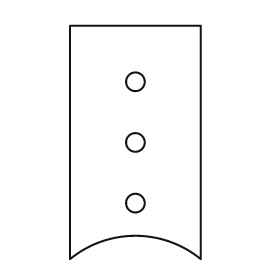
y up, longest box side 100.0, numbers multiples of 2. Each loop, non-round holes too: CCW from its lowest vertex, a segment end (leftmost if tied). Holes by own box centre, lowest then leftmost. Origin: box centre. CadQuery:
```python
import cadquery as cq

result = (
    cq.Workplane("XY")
    .moveTo(-28.0, -50.0)
    .threePointArc((0.0, -40.0), (28.0, -50.0))
    .lineTo(28.0, 50.0)
    .lineTo(-28.0, 50.0)
    .close()
    .moveTo(0.0, -26.0)
    .circle(4.0)
    .moveTo(0.0, 0.0)
    .circle(4.0)
    .moveTo(0.0, 26.0)
    .circle(4.0)
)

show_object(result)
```